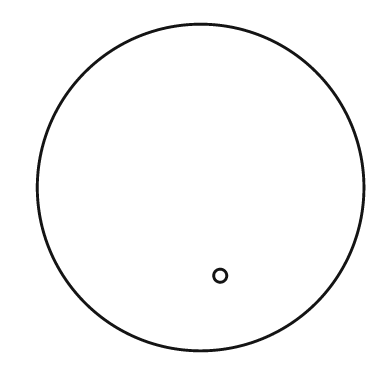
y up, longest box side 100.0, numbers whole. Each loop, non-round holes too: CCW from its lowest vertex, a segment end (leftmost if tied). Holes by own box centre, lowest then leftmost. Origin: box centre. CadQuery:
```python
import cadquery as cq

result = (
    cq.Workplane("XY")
    .moveTo(0.0, 0.0)
    .circle(50.0)
    .moveTo(6.0, -27.0)
    .circle(2.0)
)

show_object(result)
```